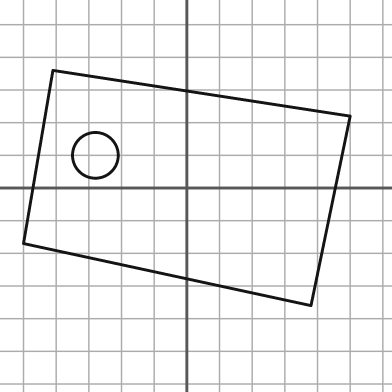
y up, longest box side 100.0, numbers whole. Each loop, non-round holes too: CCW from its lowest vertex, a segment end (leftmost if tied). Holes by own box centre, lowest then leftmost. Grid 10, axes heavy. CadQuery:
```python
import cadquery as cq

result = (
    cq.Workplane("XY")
    .moveTo(38.0, -36.0)
    .lineTo(50.0, 22.0)
    .lineTo(-41.0, 36.0)
    .lineTo(-50.0, -17.0)
    .close()
    .moveTo(-28.0, 10.0)
    .circle(7.0)
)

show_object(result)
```